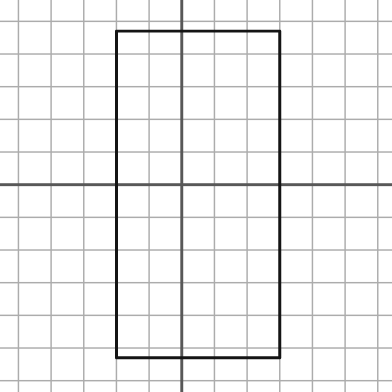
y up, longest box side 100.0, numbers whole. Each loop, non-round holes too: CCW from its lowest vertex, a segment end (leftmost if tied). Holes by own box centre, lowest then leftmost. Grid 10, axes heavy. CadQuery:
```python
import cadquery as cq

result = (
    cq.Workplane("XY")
    .moveTo(-20.0, -53.0)
    .lineTo(30.0, -53.0)
    .lineTo(30.0, 47.0)
    .lineTo(-20.0, 47.0)
    .close()
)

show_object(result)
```